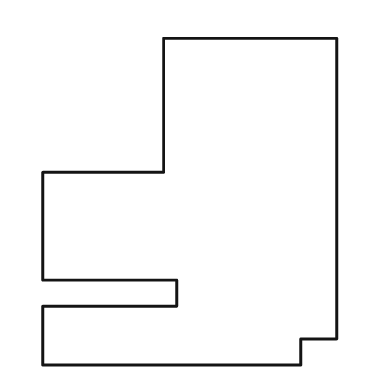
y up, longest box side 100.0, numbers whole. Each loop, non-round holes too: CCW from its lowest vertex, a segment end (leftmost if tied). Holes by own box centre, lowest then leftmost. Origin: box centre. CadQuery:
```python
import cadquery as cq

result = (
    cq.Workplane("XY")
    .moveTo(-45.0, -50.0)
    .lineTo(34.0, -50.0)
    .lineTo(34.0, -42.0)
    .lineTo(45.0, -42.0)
    .lineTo(45.0, 50.0)
    .lineTo(-8.0, 50.0)
    .lineTo(-8.0, 9.0)
    .lineTo(-45.0, 9.0)
    .lineTo(-45.0, -24.0)
    .lineTo(-4.0, -24.0)
    .lineTo(-4.0, -32.0)
    .lineTo(-45.0, -32.0)
    .close()
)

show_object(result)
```